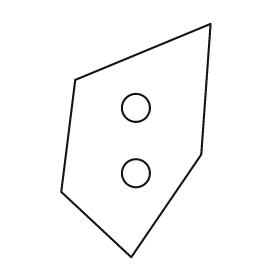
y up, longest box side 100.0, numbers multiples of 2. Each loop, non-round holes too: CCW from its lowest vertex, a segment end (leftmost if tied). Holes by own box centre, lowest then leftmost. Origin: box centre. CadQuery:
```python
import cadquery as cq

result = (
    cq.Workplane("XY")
    .moveTo(-2.0, -50.0)
    .lineTo(28.0, -6.0)
    .lineTo(32.0, 50.0)
    .lineTo(-26.0, 26.0)
    .lineTo(-32.0, -22.0)
    .close()
    .moveTo(0.0, -14.0)
    .circle(6.0)
    .moveTo(0.0, 14.0)
    .circle(6.0)
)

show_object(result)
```